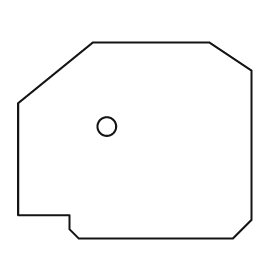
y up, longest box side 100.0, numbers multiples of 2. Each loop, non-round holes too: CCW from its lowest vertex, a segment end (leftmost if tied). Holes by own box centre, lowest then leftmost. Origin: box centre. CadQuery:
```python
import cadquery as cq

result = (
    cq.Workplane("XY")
    .moveTo(-24.0, -42.0)
    .lineTo(42.0, -42.0)
    .lineTo(50.0, -34.0)
    .lineTo(50.0, 30.0)
    .lineTo(32.0, 42.0)
    .lineTo(-18.0, 42.0)
    .lineTo(-50.0, 16.0)
    .lineTo(-50.0, -32.0)
    .lineTo(-28.0, -32.0)
    .lineTo(-28.0, -38.0)
    .close()
    .moveTo(-12.0, 6.0)
    .circle(4.0)
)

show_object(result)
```